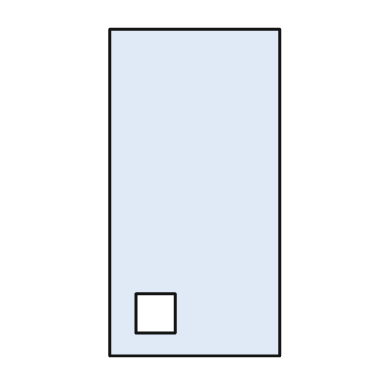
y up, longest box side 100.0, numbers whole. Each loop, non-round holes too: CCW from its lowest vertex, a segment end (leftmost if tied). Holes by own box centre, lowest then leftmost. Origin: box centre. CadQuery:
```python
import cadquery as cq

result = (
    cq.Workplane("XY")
    .moveTo(-26.0, -50.0)
    .lineTo(26.0, -50.0)
    .lineTo(26.0, 50.0)
    .lineTo(-26.0, 50.0)
    .close()
    .moveTo(-18.0, -43.0)
    .lineTo(-6.0, -43.0)
    .lineTo(-6.0, -31.0)
    .lineTo(-18.0, -31.0)
    .close()
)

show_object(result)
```